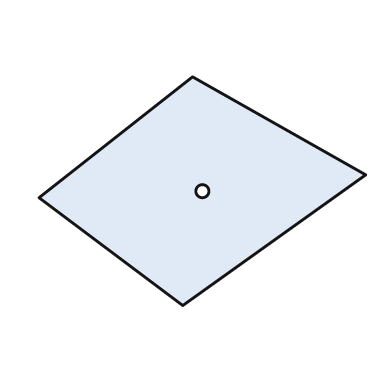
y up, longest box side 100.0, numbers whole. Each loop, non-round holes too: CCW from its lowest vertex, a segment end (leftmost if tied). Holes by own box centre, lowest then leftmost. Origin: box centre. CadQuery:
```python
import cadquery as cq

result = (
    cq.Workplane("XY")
    .moveTo(-6.0, -35.0)
    .lineTo(50.0, 5.0)
    .lineTo(-3.0, 35.0)
    .lineTo(-50.0, -2.0)
    .close()
    .moveTo(0.0, 0.0)
    .circle(2.0)
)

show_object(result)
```